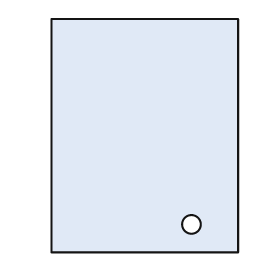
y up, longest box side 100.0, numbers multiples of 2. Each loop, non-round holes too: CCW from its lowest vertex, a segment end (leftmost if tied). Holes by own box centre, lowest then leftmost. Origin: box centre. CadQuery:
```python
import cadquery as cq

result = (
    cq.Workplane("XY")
    .moveTo(-40.0, -50.0)
    .lineTo(40.0, -50.0)
    .lineTo(40.0, 50.0)
    .lineTo(-40.0, 50.0)
    .close()
    .moveTo(20.0, -38.0)
    .circle(4.0)
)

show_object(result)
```